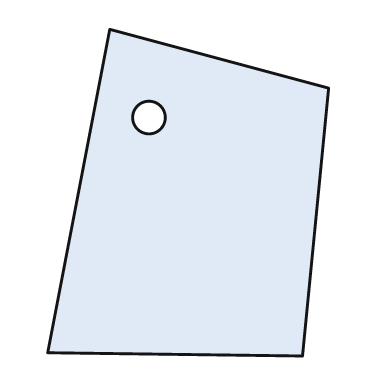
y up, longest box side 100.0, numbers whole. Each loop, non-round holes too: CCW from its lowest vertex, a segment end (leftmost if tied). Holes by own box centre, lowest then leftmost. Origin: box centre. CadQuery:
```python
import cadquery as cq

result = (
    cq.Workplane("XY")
    .moveTo(35.0, -50.0)
    .lineTo(43.0, 32.0)
    .lineTo(-24.0, 50.0)
    .lineTo(-43.0, -49.0)
    .close()
    .moveTo(-12.0, 23.0)
    .circle(5.0)
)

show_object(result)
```